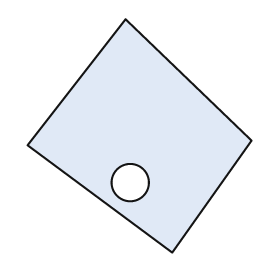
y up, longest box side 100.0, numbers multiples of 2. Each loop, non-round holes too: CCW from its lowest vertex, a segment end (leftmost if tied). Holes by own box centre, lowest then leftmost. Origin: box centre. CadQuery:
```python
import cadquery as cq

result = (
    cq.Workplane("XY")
    .moveTo(14.0, -50.0)
    .lineTo(48.0, -2.0)
    .lineTo(-6.0, 50.0)
    .lineTo(-48.0, -4.0)
    .close()
    .moveTo(-4.0, -20.0)
    .circle(8.0)
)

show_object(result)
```